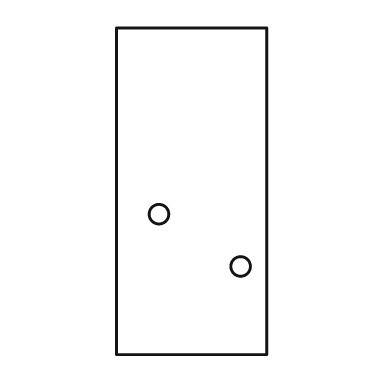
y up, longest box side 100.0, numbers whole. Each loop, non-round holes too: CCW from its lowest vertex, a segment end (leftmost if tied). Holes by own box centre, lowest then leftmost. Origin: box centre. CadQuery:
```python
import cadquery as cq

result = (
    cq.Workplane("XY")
    .moveTo(-23.0, -50.0)
    .lineTo(23.0, -50.0)
    .lineTo(23.0, 50.0)
    .lineTo(-23.0, 50.0)
    .close()
    .moveTo(15.0, -23.0)
    .circle(3.0)
    .moveTo(-10.0, -7.0)
    .circle(3.0)
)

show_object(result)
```